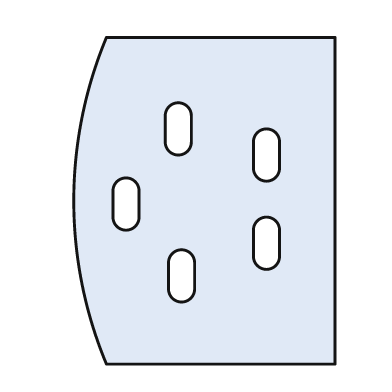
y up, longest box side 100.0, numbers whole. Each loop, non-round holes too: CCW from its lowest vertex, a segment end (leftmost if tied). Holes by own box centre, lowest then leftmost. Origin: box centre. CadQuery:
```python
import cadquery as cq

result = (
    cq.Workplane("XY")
    .moveTo(-30.0, -50.0)
    .lineTo(40.0, -50.0)
    .lineTo(40.0, 50.0)
    .lineTo(-30.0, 50.0)
    .threePointArc((-40.0, 0.0), (-30.0, -50.0))
    .close()
    .moveTo(-11.0, -27.0)
    .threePointArc((-7.0, -31.0), (-3.0, -27.0))
    .lineTo(-3.0, -19.0)
    .threePointArc((-7.0, -15.0), (-11.0, -19.0))
    .close()
    .moveTo(15.0, -17.0)
    .threePointArc((19.0, -21.0), (23.0, -17.0))
    .lineTo(23.0, -9.0)
    .threePointArc((19.0, -5.0), (15.0, -9.0))
    .close()
    .moveTo(-28.0, -5.0)
    .threePointArc((-24.0, -9.0), (-20.0, -5.0))
    .lineTo(-20.0, 3.0)
    .threePointArc((-24.0, 7.0), (-28.0, 3.0))
    .close()
    .moveTo(15.0, 10.0)
    .threePointArc((19.0, 6.0), (23.0, 10.0))
    .lineTo(23.0, 18.0)
    .threePointArc((19.0, 22.0), (15.0, 18.0))
    .close()
    .moveTo(-12.0, 18.0)
    .threePointArc((-8.0, 14.0), (-4.0, 18.0))
    .lineTo(-4.0, 26.0)
    .threePointArc((-8.0, 30.0), (-12.0, 26.0))
    .close()
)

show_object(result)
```